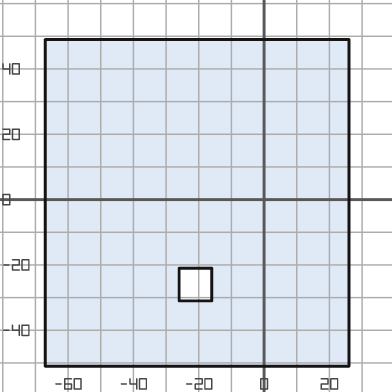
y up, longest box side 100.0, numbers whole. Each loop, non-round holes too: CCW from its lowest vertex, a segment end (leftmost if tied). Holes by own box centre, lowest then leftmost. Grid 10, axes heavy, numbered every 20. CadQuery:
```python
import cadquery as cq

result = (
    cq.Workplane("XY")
    .moveTo(-67.0, -51.0)
    .lineTo(26.0, -51.0)
    .lineTo(26.0, 49.0)
    .lineTo(-67.0, 49.0)
    .close()
    .moveTo(-26.0, -31.0)
    .lineTo(-16.0, -31.0)
    .lineTo(-16.0, -21.0)
    .lineTo(-26.0, -21.0)
    .close()
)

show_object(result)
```